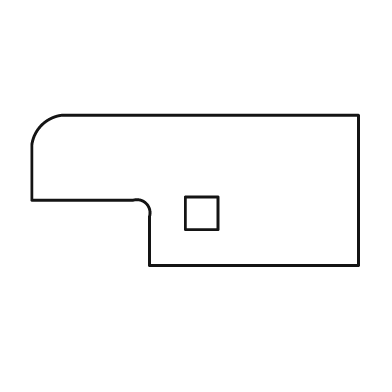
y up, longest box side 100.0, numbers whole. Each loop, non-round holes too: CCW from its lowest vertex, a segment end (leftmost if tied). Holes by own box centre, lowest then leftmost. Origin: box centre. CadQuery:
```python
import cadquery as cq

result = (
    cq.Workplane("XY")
    .moveTo(-14.0, -23.0)
    .lineTo(50.0, -23.0)
    .lineTo(50.0, 23.0)
    .lineTo(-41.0, 23.0)
    .threePointArc((-47.0, 20.0), (-50.0, 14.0))
    .lineTo(-50.0, -3.0)
    .lineTo(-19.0, -3.0)
    .threePointArc((-15.0, -4.0), (-14.0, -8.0))
    .close()
    .moveTo(-3.0, -12.0)
    .lineTo(7.0, -12.0)
    .lineTo(7.0, -2.0)
    .lineTo(-3.0, -2.0)
    .close()
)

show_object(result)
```